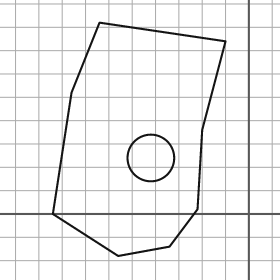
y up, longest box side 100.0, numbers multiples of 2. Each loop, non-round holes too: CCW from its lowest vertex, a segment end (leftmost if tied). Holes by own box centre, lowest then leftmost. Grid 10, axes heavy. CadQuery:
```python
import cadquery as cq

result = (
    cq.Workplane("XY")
    .moveTo(-56.0, -18.0)
    .lineTo(-34.0, -14.0)
    .lineTo(-22.0, 2.0)
    .lineTo(-20.0, 36.0)
    .lineTo(-10.0, 74.0)
    .lineTo(-64.0, 82.0)
    .lineTo(-76.0, 52.0)
    .lineTo(-84.0, 0.0)
    .close()
    .moveTo(-42.0, 24.0)
    .circle(10.0)
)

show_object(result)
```